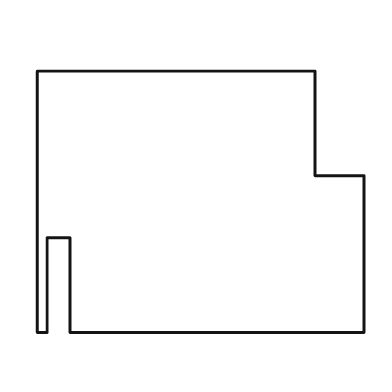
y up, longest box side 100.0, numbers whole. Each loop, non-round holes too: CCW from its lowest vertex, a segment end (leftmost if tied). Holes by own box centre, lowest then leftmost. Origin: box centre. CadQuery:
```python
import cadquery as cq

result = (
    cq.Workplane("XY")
    .moveTo(-50.0, -40.0)
    .lineTo(-47.0, -40.0)
    .lineTo(-47.0, -11.0)
    .lineTo(-40.0, -11.0)
    .lineTo(-40.0, -40.0)
    .lineTo(50.0, -40.0)
    .lineTo(50.0, 8.0)
    .lineTo(35.0, 8.0)
    .lineTo(35.0, 40.0)
    .lineTo(-50.0, 40.0)
    .close()
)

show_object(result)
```